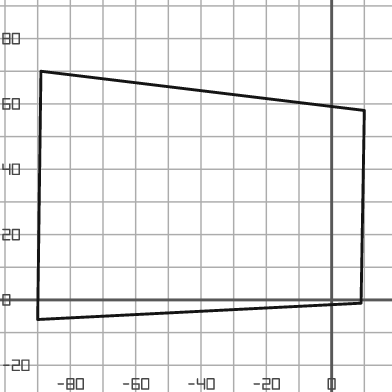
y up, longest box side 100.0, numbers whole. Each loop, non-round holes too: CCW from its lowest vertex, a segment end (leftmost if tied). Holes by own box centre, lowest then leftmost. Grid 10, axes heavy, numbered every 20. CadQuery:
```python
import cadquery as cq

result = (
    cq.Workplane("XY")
    .moveTo(-90.0, -6.0)
    .lineTo(9.0, -1.0)
    .lineTo(10.0, 58.0)
    .lineTo(-89.0, 70.0)
    .close()
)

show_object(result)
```